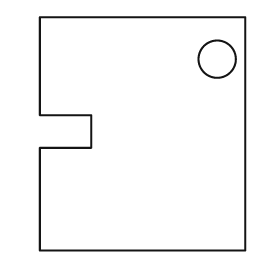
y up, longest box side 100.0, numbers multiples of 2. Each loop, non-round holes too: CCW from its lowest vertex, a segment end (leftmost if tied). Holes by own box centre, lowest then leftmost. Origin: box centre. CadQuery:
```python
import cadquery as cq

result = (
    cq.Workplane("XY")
    .moveTo(-44.0, -50.0)
    .lineTo(44.0, -50.0)
    .lineTo(44.0, 50.0)
    .lineTo(-44.0, 50.0)
    .lineTo(-44.0, 8.0)
    .lineTo(-22.0, 8.0)
    .lineTo(-22.0, -6.0)
    .lineTo(-44.0, -6.0)
    .close()
    .moveTo(32.0, 32.0)
    .circle(8.0)
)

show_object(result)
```